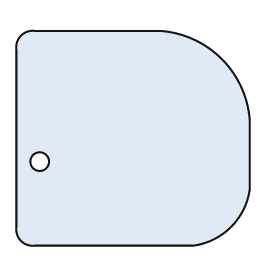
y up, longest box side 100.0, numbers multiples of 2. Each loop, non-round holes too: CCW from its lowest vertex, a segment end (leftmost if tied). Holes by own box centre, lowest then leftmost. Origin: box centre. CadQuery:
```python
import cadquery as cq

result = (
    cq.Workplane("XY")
    .moveTo(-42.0, -46.0)
    .lineTo(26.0, -46.0)
    .threePointArc((42.0, -38.0), (50.0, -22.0))
    .lineTo(50.0, 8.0)
    .threePointArc((38.0, 34.0), (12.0, 46.0))
    .lineTo(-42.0, 46.0)
    .threePointArc((-48.0, 44.0), (-50.0, 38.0))
    .lineTo(-50.0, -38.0)
    .threePointArc((-48.0, -44.0), (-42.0, -46.0))
    .close()
    .moveTo(-40.0, -10.0)
    .circle(4.0)
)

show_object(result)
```